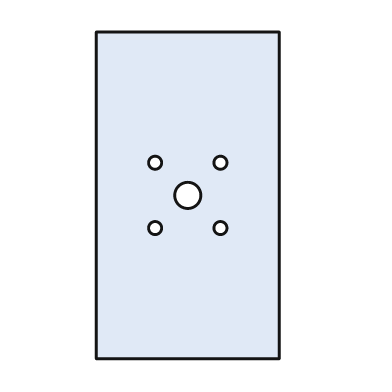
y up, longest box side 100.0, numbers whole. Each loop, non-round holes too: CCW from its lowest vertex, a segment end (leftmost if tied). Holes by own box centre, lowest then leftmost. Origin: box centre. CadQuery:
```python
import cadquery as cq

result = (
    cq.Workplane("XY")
    .moveTo(-28.0, -50.0)
    .lineTo(28.0, -50.0)
    .lineTo(28.0, 50.0)
    .lineTo(-28.0, 50.0)
    .close()
    .moveTo(-10.0, -10.0)
    .circle(2.0)
    .moveTo(10.0, -10.0)
    .circle(2.0)
    .moveTo(0.0, 0.0)
    .circle(4.0)
    .moveTo(-10.0, 10.0)
    .circle(2.0)
    .moveTo(10.0, 10.0)
    .circle(2.0)
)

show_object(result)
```